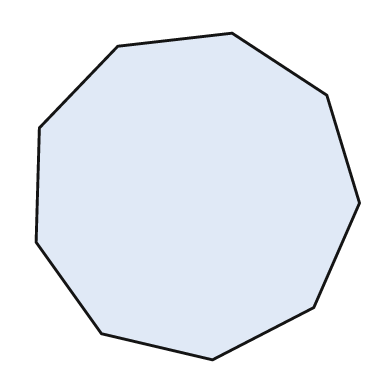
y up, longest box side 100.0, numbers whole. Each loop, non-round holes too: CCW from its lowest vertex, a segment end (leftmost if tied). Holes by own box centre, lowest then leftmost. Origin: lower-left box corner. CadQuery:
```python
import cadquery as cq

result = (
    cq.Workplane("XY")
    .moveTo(54.0, 0.0)
    .lineTo(85.0, 16.0)
    .lineTo(99.0, 48.0)
    .lineTo(89.0, 81.0)
    .lineTo(60.0, 100.0)
    .lineTo(25.0, 96.0)
    .lineTo(1.0, 71.0)
    .lineTo(0.0, 36.0)
    .lineTo(20.0, 8.0)
    .close()
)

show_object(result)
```